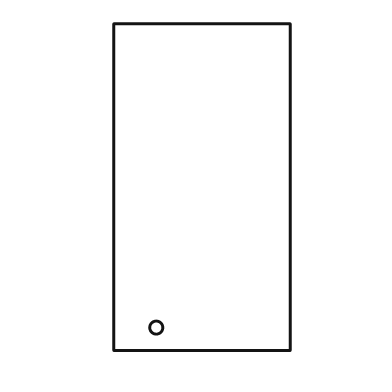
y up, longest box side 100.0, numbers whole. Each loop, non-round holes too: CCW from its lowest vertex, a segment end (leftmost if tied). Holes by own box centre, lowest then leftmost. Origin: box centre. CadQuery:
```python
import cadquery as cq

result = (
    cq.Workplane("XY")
    .moveTo(-27.0, -50.0)
    .lineTo(27.0, -50.0)
    .lineTo(27.0, 50.0)
    .lineTo(-27.0, 50.0)
    .close()
    .moveTo(-14.0, -43.0)
    .circle(2.0)
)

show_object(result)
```